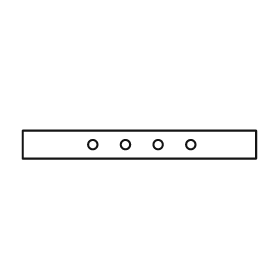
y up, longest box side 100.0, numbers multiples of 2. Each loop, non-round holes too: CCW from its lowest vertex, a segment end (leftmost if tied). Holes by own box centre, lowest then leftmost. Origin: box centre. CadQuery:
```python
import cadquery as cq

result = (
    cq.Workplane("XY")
    .moveTo(-50.0, -6.0)
    .lineTo(50.0, -6.0)
    .lineTo(50.0, 6.0)
    .lineTo(-50.0, 6.0)
    .close()
    .moveTo(-20.0, 0.0)
    .circle(2.0)
    .moveTo(-6.0, 0.0)
    .circle(2.0)
    .moveTo(8.0, 0.0)
    .circle(2.0)
    .moveTo(22.0, 0.0)
    .circle(2.0)
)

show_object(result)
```